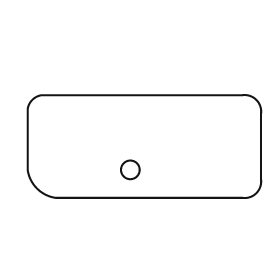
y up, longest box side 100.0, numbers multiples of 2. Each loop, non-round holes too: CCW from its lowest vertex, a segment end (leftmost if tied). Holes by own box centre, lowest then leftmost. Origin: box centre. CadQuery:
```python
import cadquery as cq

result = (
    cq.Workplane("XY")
    .moveTo(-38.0, -22.0)
    .lineTo(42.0, -22.0)
    .threePointArc((48.0, -20.0), (50.0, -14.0))
    .lineTo(50.0, 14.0)
    .threePointArc((48.0, 20.0), (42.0, 22.0))
    .lineTo(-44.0, 22.0)
    .threePointArc((-48.0, 20.0), (-50.0, 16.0))
    .lineTo(-50.0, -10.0)
    .threePointArc((-46.0, -18.0), (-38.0, -22.0))
    .close()
    .moveTo(-6.0, -10.0)
    .circle(4.0)
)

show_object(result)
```